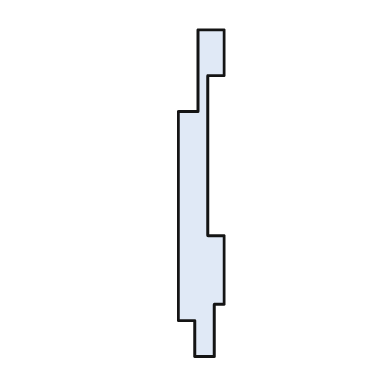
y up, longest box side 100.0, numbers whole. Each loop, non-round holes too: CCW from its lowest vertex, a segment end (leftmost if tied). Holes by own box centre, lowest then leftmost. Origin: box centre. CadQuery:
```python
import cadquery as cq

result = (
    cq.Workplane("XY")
    .moveTo(-2.0, -50.0)
    .lineTo(4.0, -50.0)
    .lineTo(4.0, -34.0)
    .lineTo(7.0, -34.0)
    .lineTo(7.0, -13.0)
    .lineTo(2.0, -13.0)
    .lineTo(2.0, 36.0)
    .lineTo(7.0, 36.0)
    .lineTo(7.0, 50.0)
    .lineTo(-1.0, 50.0)
    .lineTo(-1.0, 25.0)
    .lineTo(-7.0, 25.0)
    .lineTo(-7.0, -39.0)
    .lineTo(-2.0, -39.0)
    .close()
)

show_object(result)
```